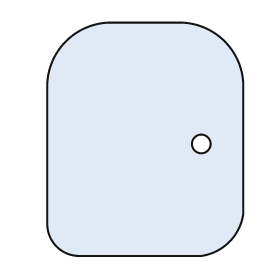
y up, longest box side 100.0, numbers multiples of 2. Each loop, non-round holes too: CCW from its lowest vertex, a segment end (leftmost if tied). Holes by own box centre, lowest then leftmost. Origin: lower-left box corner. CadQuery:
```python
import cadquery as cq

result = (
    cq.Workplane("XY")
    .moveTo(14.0, 0.0)
    .lineTo(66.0, 0.0)
    .threePointArc((78.0, 6.0), (84.0, 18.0))
    .lineTo(84.0, 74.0)
    .threePointArc((76.0, 92.0), (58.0, 100.0))
    .lineTo(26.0, 100.0)
    .threePointArc((8.0, 92.0), (0.0, 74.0))
    .lineTo(0.0, 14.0)
    .threePointArc((4.0, 4.0), (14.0, 0.0))
    .close()
    .moveTo(66.0, 48.0)
    .circle(4.0)
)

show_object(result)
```